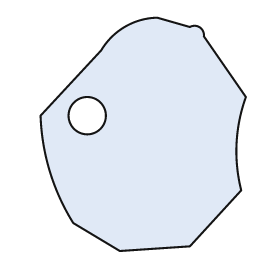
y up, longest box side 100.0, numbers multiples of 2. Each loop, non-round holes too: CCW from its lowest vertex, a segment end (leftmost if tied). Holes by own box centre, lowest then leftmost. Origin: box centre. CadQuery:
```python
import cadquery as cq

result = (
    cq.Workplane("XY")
    .moveTo(-10.0, -50.0)
    .lineTo(20.0, -48.0)
    .lineTo(42.0, -24.0)
    .threePointArc((40.0, -4.0), (44.0, 16.0))
    .lineTo(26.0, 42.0)
    .threePointArc((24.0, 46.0), (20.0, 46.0))
    .lineTo(6.0, 50.0)
    .threePointArc((-8.0, 46.0), (-18.0, 36.0))
    .lineTo(-44.0, 8.0)
    .threePointArc((-40.0, -16.0), (-30.0, -38.0))
    .close()
    .moveTo(-24.0, 8.0)
    .circle(8.0)
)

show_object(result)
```